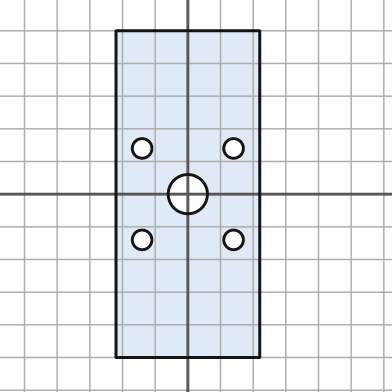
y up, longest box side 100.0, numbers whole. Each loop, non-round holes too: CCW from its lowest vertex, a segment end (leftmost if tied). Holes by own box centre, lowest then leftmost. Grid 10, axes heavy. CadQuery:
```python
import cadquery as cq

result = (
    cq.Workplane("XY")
    .moveTo(-22.0, -50.0)
    .lineTo(22.0, -50.0)
    .lineTo(22.0, 50.0)
    .lineTo(-22.0, 50.0)
    .close()
    .moveTo(-14.0, -14.0)
    .circle(3.0)
    .moveTo(14.0, -14.0)
    .circle(3.0)
    .moveTo(0.0, 0.0)
    .circle(6.0)
    .moveTo(-14.0, 14.0)
    .circle(3.0)
    .moveTo(14.0, 14.0)
    .circle(3.0)
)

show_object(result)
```